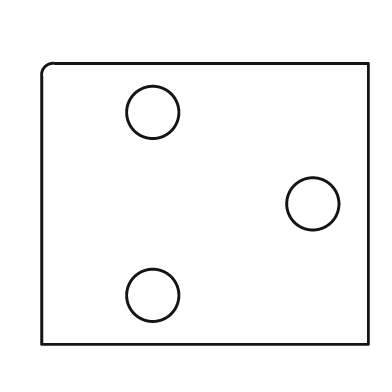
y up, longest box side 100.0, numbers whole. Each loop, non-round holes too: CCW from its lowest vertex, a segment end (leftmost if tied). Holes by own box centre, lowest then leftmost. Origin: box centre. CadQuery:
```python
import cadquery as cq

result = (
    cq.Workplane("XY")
    .moveTo(-50.0, -43.0)
    .lineTo(50.0, -43.0)
    .lineTo(50.0, 43.0)
    .lineTo(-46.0, 43.0)
    .threePointArc((-49.0, 42.0), (-50.0, 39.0))
    .close()
    .moveTo(-16.0, -28.0)
    .circle(8.0)
    .moveTo(33.0, 0.0)
    .circle(8.0)
    .moveTo(-16.0, 28.0)
    .circle(8.0)
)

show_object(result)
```